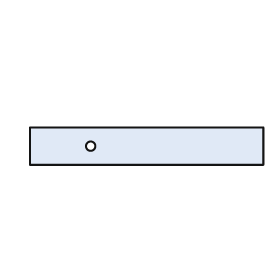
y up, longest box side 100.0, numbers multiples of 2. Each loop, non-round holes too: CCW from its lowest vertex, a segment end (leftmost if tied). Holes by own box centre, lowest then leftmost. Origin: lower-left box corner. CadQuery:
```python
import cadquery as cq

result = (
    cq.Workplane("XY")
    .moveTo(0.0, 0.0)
    .lineTo(100.0, 0.0)
    .lineTo(100.0, 16.0)
    .lineTo(0.0, 16.0)
    .close()
    .moveTo(26.0, 8.0)
    .circle(2.0)
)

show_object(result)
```